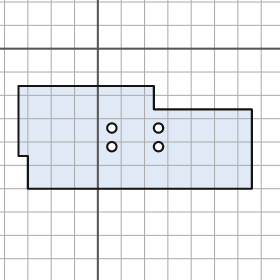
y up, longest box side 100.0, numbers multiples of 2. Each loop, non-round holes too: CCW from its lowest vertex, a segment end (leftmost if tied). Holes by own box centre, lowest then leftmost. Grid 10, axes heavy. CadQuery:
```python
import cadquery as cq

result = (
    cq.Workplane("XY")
    .moveTo(-30.0, -60.0)
    .lineTo(66.0, -60.0)
    .lineTo(66.0, -26.0)
    .lineTo(24.0, -26.0)
    .lineTo(24.0, -16.0)
    .lineTo(-34.0, -16.0)
    .lineTo(-34.0, -46.0)
    .lineTo(-30.0, -46.0)
    .close()
    .moveTo(6.0, -42.0)
    .circle(2.0)
    .moveTo(26.0, -42.0)
    .circle(2.0)
    .moveTo(6.0, -34.0)
    .circle(2.0)
    .moveTo(26.0, -34.0)
    .circle(2.0)
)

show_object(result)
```